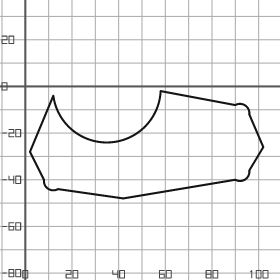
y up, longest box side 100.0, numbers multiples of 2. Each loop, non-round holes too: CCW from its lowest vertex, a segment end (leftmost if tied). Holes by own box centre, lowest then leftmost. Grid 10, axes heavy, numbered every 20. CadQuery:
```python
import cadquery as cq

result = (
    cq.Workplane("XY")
    .moveTo(42.0, -48.0)
    .lineTo(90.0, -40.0)
    .threePointArc((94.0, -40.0), (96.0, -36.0))
    .lineTo(102.0, -26.0)
    .lineTo(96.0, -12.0)
    .threePointArc((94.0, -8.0), (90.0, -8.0))
    .lineTo(58.0, -2.0)
    .threePointArc((36.0, -24.0), (12.0, -4.0))
    .lineTo(2.0, -28.0)
    .lineTo(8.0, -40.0)
    .threePointArc((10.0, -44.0), (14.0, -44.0))
    .close()
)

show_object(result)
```